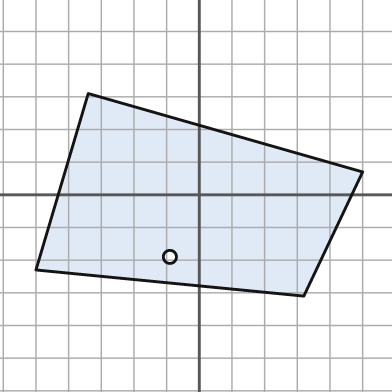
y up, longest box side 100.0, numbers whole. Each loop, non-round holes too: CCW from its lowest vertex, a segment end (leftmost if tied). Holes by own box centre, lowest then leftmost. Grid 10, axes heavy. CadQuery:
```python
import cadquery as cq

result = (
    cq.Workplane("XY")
    .moveTo(32.0, -31.0)
    .lineTo(50.0, 7.0)
    .lineTo(-34.0, 31.0)
    .lineTo(-50.0, -23.0)
    .close()
    .moveTo(-9.0, -19.0)
    .circle(2.0)
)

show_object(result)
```